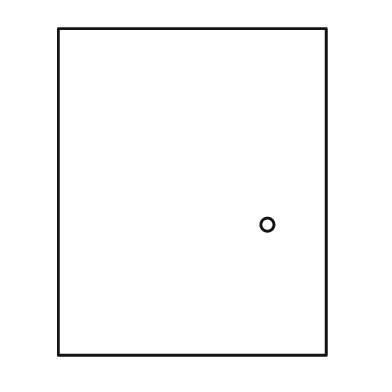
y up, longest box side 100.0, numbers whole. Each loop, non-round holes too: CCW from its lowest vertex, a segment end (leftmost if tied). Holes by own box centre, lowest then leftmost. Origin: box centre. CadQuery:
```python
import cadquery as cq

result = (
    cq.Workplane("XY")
    .moveTo(-41.0, -50.0)
    .lineTo(41.0, -50.0)
    .lineTo(41.0, 50.0)
    .lineTo(-41.0, 50.0)
    .close()
    .moveTo(23.0, -10.0)
    .circle(2.0)
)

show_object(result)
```